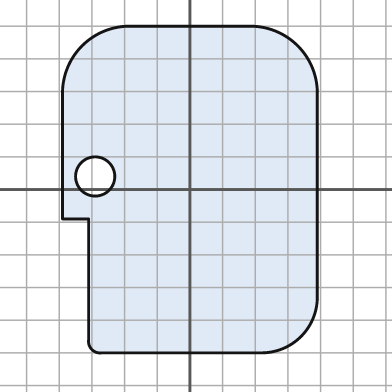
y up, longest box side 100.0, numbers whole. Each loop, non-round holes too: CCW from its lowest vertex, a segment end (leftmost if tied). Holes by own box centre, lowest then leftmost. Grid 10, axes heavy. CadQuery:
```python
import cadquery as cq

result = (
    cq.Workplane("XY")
    .moveTo(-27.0, -50.0)
    .lineTo(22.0, -50.0)
    .threePointArc((34.0, -45.0), (39.0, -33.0))
    .lineTo(39.0, 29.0)
    .threePointArc((33.0, 44.0), (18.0, 50.0))
    .lineTo(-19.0, 50.0)
    .threePointArc((-33.0, 44.0), (-39.0, 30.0))
    .lineTo(-39.0, -9.0)
    .lineTo(-31.0, -9.0)
    .lineTo(-31.0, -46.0)
    .threePointArc((-30.0, -49.0), (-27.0, -50.0))
    .close()
    .moveTo(-29.0, 4.0)
    .circle(6.0)
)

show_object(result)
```